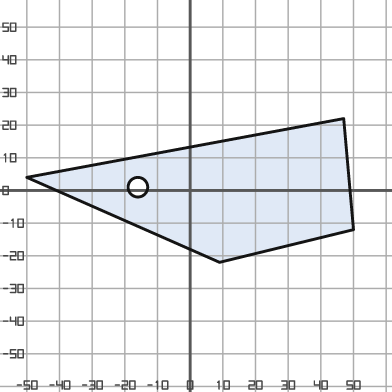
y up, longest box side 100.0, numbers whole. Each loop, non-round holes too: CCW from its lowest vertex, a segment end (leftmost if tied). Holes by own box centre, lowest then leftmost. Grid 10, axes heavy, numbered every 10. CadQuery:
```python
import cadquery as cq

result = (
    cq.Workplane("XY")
    .moveTo(9.0, -22.0)
    .lineTo(50.0, -12.0)
    .lineTo(47.0, 22.0)
    .lineTo(-50.0, 4.0)
    .close()
    .moveTo(-16.0, 1.0)
    .circle(3.0)
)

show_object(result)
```